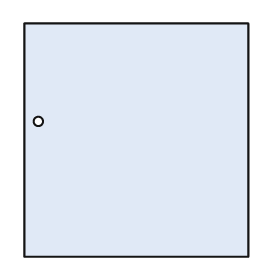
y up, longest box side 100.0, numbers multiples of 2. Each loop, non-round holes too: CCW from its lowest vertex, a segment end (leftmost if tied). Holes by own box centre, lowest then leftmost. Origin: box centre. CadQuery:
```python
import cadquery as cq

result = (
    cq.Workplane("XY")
    .moveTo(-48.0, -50.0)
    .lineTo(48.0, -50.0)
    .lineTo(48.0, 50.0)
    .lineTo(-48.0, 50.0)
    .close()
    .moveTo(-42.0, 8.0)
    .circle(2.0)
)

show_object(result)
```